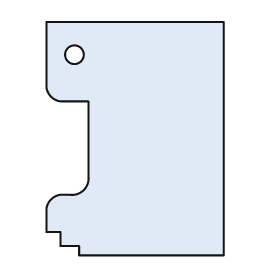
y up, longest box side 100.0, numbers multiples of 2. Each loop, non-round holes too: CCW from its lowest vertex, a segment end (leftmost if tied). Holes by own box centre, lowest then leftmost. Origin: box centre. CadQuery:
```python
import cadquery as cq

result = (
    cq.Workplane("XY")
    .moveTo(-24.0, -50.0)
    .lineTo(38.0, -50.0)
    .lineTo(38.0, 50.0)
    .lineTo(-38.0, 50.0)
    .lineTo(-38.0, 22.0)
    .threePointArc((-36.0, 18.0), (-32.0, 16.0))
    .lineTo(-20.0, 16.0)
    .lineTo(-20.0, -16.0)
    .threePointArc((-22.0, -22.0), (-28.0, -24.0))
    .lineTo(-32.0, -24.0)
    .threePointArc((-36.0, -26.0), (-38.0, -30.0))
    .lineTo(-38.0, -40.0)
    .lineTo(-32.0, -40.0)
    .lineTo(-32.0, -46.0)
    .lineTo(-24.0, -46.0)
    .close()
    .moveTo(-26.0, 36.0)
    .circle(4.0)
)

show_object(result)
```